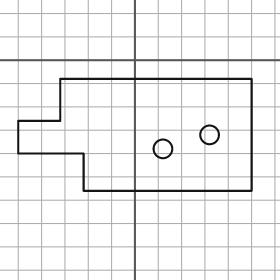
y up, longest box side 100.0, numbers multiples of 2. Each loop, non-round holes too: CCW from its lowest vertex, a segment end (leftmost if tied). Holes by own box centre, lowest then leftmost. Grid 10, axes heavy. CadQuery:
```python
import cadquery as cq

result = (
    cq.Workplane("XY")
    .moveTo(-22.0, -56.0)
    .lineTo(50.0, -56.0)
    .lineTo(50.0, -8.0)
    .lineTo(-32.0, -8.0)
    .lineTo(-32.0, -26.0)
    .lineTo(-50.0, -26.0)
    .lineTo(-50.0, -40.0)
    .lineTo(-22.0, -40.0)
    .close()
    .moveTo(12.0, -38.0)
    .circle(4.0)
    .moveTo(32.0, -32.0)
    .circle(4.0)
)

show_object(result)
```